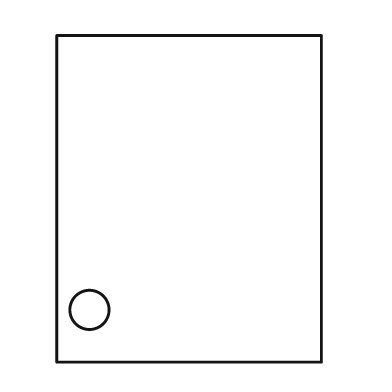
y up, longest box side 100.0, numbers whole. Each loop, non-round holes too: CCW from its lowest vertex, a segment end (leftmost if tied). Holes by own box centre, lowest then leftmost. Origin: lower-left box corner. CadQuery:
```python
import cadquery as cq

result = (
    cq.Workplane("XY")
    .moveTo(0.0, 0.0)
    .lineTo(81.0, 0.0)
    .lineTo(81.0, 100.0)
    .lineTo(0.0, 100.0)
    .close()
    .moveTo(10.0, 16.0)
    .circle(6.0)
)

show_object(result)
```